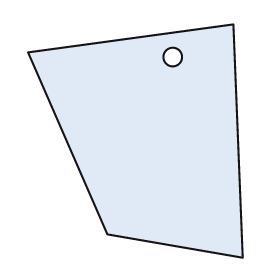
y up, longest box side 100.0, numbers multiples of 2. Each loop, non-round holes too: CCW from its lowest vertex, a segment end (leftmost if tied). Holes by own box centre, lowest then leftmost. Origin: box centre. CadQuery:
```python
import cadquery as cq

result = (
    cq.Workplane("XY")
    .moveTo(46.0, -50.0)
    .lineTo(42.0, 50.0)
    .lineTo(-46.0, 38.0)
    .lineTo(-12.0, -40.0)
    .close()
    .moveTo(16.0, 36.0)
    .circle(4.0)
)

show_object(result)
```